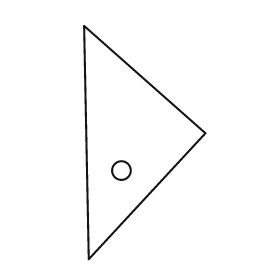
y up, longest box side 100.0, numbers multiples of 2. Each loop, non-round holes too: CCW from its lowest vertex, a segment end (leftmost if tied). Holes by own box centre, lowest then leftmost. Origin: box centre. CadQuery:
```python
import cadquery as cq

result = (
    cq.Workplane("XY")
    .moveTo(-24.0, -50.0)
    .lineTo(26.0, 4.0)
    .lineTo(-26.0, 50.0)
    .close()
    .moveTo(-10.0, -12.0)
    .circle(4.0)
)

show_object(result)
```